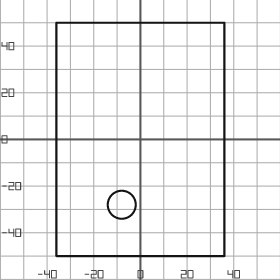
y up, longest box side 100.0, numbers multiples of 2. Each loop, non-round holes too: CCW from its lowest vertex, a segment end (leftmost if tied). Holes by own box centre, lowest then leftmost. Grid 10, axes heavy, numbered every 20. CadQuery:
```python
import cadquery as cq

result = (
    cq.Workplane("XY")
    .moveTo(-36.0, -50.0)
    .lineTo(36.0, -50.0)
    .lineTo(36.0, 50.0)
    .lineTo(-36.0, 50.0)
    .close()
    .moveTo(-8.0, -28.0)
    .circle(6.0)
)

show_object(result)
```